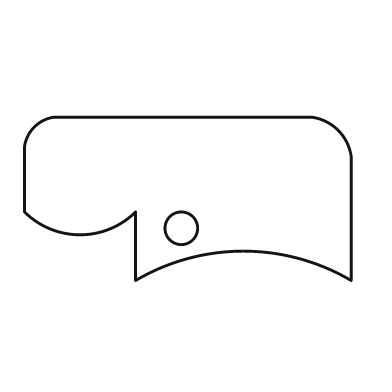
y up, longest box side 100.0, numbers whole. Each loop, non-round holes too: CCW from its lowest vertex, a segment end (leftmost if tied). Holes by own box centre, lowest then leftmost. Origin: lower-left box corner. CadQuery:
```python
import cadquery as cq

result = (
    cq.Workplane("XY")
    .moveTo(34.0, 0.0)
    .threePointArc((67.0, 9.0), (100.0, 0.0))
    .lineTo(100.0, 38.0)
    .threePointArc((96.0, 46.0), (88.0, 50.0))
    .lineTo(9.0, 50.0)
    .threePointArc((3.0, 47.0), (0.0, 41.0))
    .lineTo(0.0, 21.0)
    .threePointArc((17.0, 14.0), (34.0, 21.0))
    .close()
    .moveTo(48.0, 16.0)
    .circle(5.0)
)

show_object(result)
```